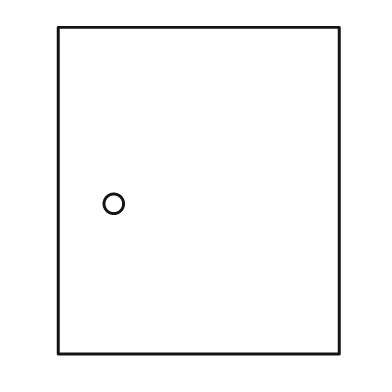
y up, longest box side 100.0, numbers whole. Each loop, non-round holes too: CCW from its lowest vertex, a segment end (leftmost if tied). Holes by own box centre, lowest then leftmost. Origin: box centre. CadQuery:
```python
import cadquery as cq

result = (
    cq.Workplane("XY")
    .moveTo(-43.0, -50.0)
    .lineTo(43.0, -50.0)
    .lineTo(43.0, 50.0)
    .lineTo(-43.0, 50.0)
    .close()
    .moveTo(-26.0, -4.0)
    .circle(3.0)
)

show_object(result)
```